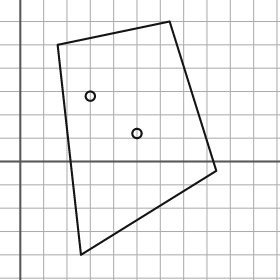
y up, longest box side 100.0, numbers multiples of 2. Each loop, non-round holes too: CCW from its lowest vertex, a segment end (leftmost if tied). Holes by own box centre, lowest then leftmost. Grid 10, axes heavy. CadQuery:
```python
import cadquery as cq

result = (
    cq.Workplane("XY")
    .moveTo(26.0, -40.0)
    .lineTo(84.0, -4.0)
    .lineTo(64.0, 60.0)
    .lineTo(16.0, 50.0)
    .close()
    .moveTo(50.0, 12.0)
    .circle(2.0)
    .moveTo(30.0, 28.0)
    .circle(2.0)
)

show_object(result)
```